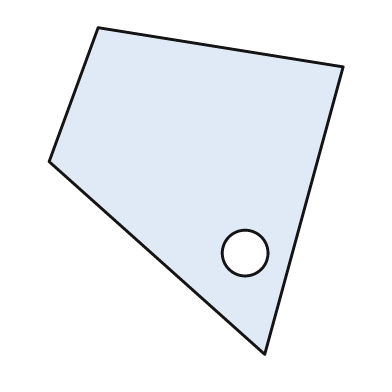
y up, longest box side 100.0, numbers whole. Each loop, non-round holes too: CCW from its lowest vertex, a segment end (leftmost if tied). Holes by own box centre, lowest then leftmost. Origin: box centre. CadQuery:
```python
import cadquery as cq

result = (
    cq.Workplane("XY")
    .moveTo(21.0, -50.0)
    .lineTo(45.0, 38.0)
    .lineTo(-30.0, 50.0)
    .lineTo(-45.0, 9.0)
    .close()
    .moveTo(15.0, -19.0)
    .circle(7.0)
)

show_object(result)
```